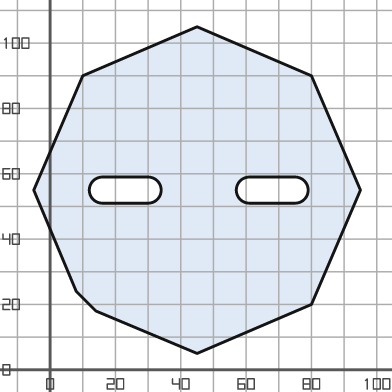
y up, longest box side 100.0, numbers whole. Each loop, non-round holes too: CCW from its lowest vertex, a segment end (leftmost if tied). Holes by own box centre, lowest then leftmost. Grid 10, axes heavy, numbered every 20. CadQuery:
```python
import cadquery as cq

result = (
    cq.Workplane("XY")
    .moveTo(45.0, 5.0)
    .lineTo(80.0, 20.0)
    .lineTo(95.0, 55.0)
    .lineTo(80.0, 90.0)
    .lineTo(45.0, 105.0)
    .lineTo(10.0, 90.0)
    .lineTo(-5.0, 55.0)
    .lineTo(8.0, 24.0)
    .lineTo(14.0, 18.0)
    .close()
    .moveTo(16.0, 51.0)
    .lineTo(30.0, 51.0)
    .threePointArc((34.0, 55.0), (30.0, 59.0))
    .lineTo(16.0, 59.0)
    .threePointArc((12.0, 55.0), (16.0, 51.0))
    .close()
    .moveTo(61.0, 51.0)
    .lineTo(75.0, 51.0)
    .threePointArc((79.0, 55.0), (75.0, 59.0))
    .lineTo(61.0, 59.0)
    .threePointArc((57.0, 55.0), (61.0, 51.0))
    .close()
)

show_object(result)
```